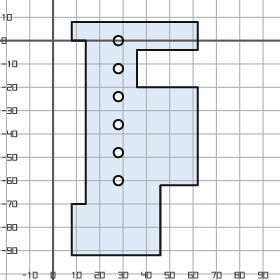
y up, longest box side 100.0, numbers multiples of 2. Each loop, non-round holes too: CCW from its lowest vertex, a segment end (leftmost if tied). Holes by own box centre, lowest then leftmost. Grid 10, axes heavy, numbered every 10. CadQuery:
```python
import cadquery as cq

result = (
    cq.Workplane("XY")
    .moveTo(8.0, -92.0)
    .lineTo(46.0, -92.0)
    .lineTo(46.0, -62.0)
    .lineTo(62.0, -62.0)
    .lineTo(62.0, -20.0)
    .lineTo(36.0, -20.0)
    .lineTo(36.0, -4.0)
    .lineTo(62.0, -4.0)
    .lineTo(62.0, 8.0)
    .lineTo(8.0, 8.0)
    .lineTo(8.0, 0.0)
    .lineTo(14.0, 0.0)
    .lineTo(14.0, -70.0)
    .lineTo(8.0, -70.0)
    .close()
    .moveTo(28.0, -60.0)
    .circle(2.0)
    .moveTo(28.0, -48.0)
    .circle(2.0)
    .moveTo(28.0, -36.0)
    .circle(2.0)
    .moveTo(28.0, -24.0)
    .circle(2.0)
    .moveTo(28.0, -12.0)
    .circle(2.0)
    .moveTo(28.0, 0.0)
    .circle(2.0)
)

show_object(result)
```